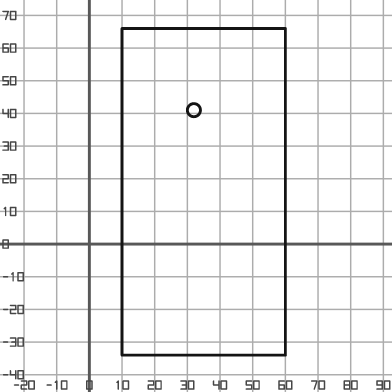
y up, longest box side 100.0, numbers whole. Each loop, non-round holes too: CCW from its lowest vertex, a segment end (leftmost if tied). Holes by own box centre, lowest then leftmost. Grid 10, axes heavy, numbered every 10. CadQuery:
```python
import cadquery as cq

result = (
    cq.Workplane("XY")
    .moveTo(10.0, -34.0)
    .lineTo(60.0, -34.0)
    .lineTo(60.0, 66.0)
    .lineTo(10.0, 66.0)
    .close()
    .moveTo(32.0, 41.0)
    .circle(2.0)
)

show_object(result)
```